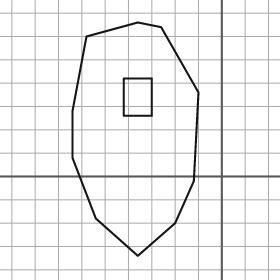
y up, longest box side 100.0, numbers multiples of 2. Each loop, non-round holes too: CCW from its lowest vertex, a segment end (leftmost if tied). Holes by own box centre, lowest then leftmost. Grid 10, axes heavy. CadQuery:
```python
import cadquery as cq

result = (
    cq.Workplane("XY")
    .moveTo(-36.0, -34.0)
    .lineTo(-20.0, -20.0)
    .lineTo(-12.0, -2.0)
    .lineTo(-10.0, 36.0)
    .lineTo(-26.0, 64.0)
    .lineTo(-36.0, 66.0)
    .lineTo(-58.0, 60.0)
    .lineTo(-64.0, 28.0)
    .lineTo(-64.0, 8.0)
    .lineTo(-54.0, -18.0)
    .close()
    .moveTo(-42.0, 26.0)
    .lineTo(-30.0, 26.0)
    .lineTo(-30.0, 42.0)
    .lineTo(-42.0, 42.0)
    .close()
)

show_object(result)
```